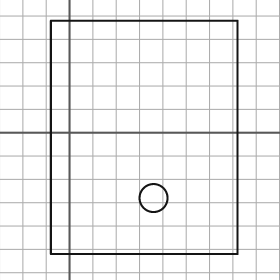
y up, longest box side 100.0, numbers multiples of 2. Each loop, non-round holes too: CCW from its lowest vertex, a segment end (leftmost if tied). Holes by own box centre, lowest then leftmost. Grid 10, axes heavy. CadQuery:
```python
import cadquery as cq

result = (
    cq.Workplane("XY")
    .moveTo(-8.0, -52.0)
    .lineTo(72.0, -52.0)
    .lineTo(72.0, 48.0)
    .lineTo(-8.0, 48.0)
    .close()
    .moveTo(36.0, -28.0)
    .circle(6.0)
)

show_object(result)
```